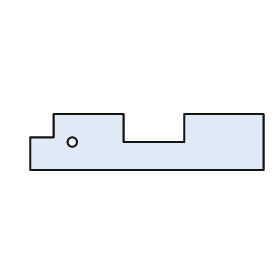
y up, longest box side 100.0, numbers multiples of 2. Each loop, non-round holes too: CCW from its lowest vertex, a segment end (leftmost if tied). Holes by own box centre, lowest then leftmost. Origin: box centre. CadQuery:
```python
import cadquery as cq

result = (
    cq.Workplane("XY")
    .moveTo(-50.0, -12.0)
    .lineTo(50.0, -12.0)
    .lineTo(50.0, 12.0)
    .lineTo(16.0, 12.0)
    .lineTo(16.0, 0.0)
    .lineTo(-10.0, 0.0)
    .lineTo(-10.0, 12.0)
    .lineTo(-40.0, 12.0)
    .lineTo(-40.0, 2.0)
    .lineTo(-50.0, 2.0)
    .close()
    .moveTo(-32.0, 0.0)
    .circle(2.0)
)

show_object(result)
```